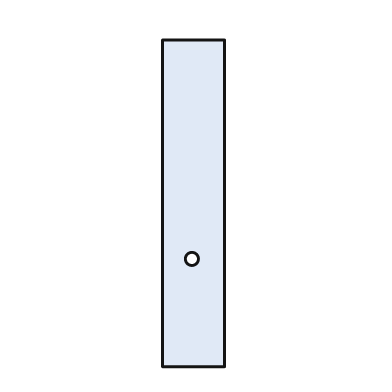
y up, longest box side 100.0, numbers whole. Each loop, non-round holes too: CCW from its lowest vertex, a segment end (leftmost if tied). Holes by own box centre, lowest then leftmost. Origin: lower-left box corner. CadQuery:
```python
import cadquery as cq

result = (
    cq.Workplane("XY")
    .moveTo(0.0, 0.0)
    .lineTo(19.0, 0.0)
    .lineTo(19.0, 100.0)
    .lineTo(0.0, 100.0)
    .close()
    .moveTo(9.0, 33.0)
    .circle(2.0)
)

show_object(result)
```